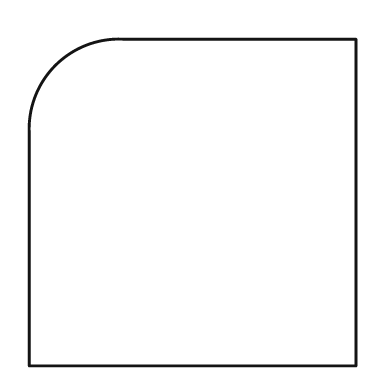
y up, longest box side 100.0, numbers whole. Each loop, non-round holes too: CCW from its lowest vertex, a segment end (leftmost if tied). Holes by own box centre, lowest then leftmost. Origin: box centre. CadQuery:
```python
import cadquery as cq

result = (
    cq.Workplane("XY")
    .moveTo(-50.0, -50.0)
    .lineTo(50.0, -50.0)
    .lineTo(50.0, 50.0)
    .lineTo(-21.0, 50.0)
    .threePointArc((-42.0, 42.0), (-50.0, 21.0))
    .close()
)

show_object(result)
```